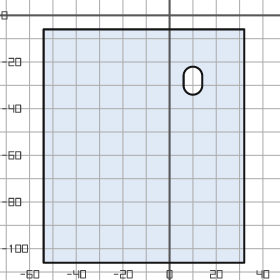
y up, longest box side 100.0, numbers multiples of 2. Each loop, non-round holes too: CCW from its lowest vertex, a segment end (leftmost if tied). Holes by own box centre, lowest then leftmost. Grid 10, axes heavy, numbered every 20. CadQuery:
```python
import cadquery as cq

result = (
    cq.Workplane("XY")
    .moveTo(-54.0, -106.0)
    .lineTo(32.0, -106.0)
    .lineTo(32.0, -6.0)
    .lineTo(-54.0, -6.0)
    .close()
    .moveTo(6.0, -30.0)
    .threePointArc((10.0, -34.0), (14.0, -30.0))
    .lineTo(14.0, -26.0)
    .threePointArc((10.0, -22.0), (6.0, -26.0))
    .close()
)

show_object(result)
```